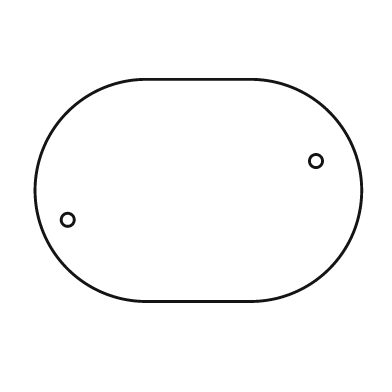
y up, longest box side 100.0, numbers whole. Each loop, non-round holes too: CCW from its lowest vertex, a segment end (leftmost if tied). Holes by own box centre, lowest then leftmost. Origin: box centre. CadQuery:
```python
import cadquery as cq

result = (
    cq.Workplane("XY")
    .moveTo(-16.0, -34.0)
    .lineTo(16.0, -34.0)
    .threePointArc((50.0, 0.0), (16.0, 34.0))
    .lineTo(-16.0, 34.0)
    .threePointArc((-50.0, 0.0), (-16.0, -34.0))
    .close()
    .moveTo(-40.0, -9.0)
    .circle(2.0)
    .moveTo(36.0, 9.0)
    .circle(2.0)
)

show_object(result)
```